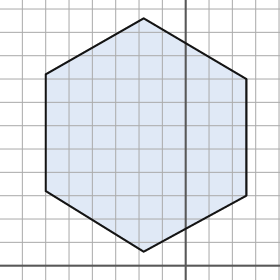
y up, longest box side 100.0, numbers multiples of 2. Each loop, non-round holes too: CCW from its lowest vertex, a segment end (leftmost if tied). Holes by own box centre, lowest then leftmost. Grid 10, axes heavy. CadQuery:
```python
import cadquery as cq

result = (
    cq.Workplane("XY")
    .moveTo(-18.0, 6.0)
    .lineTo(26.0, 30.0)
    .lineTo(26.0, 80.0)
    .lineTo(-18.0, 106.0)
    .lineTo(-60.0, 82.0)
    .lineTo(-60.0, 32.0)
    .close()
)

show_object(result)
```